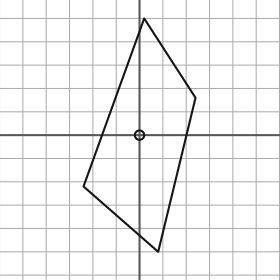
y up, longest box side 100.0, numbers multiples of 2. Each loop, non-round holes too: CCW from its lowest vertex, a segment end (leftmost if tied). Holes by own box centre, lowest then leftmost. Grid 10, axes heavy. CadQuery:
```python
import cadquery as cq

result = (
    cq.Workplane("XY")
    .moveTo(8.0, -50.0)
    .lineTo(24.0, 16.0)
    .lineTo(2.0, 50.0)
    .lineTo(-24.0, -22.0)
    .close()
    .moveTo(0.0, 0.0)
    .circle(2.0)
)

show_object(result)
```